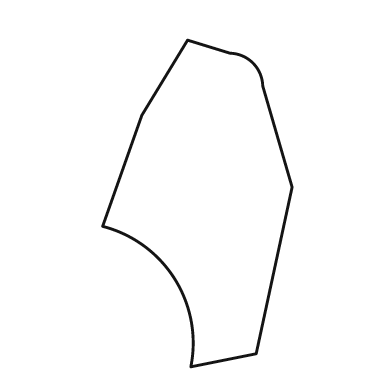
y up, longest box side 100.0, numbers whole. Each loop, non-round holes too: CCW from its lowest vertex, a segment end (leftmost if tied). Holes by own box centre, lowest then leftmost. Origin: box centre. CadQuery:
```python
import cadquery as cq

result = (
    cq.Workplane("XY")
    .moveTo(-2.0, -50.0)
    .lineTo(18.0, -46.0)
    .lineTo(29.0, 5.0)
    .lineTo(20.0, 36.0)
    .threePointArc((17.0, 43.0), (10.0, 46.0))
    .lineTo(-3.0, 50.0)
    .lineTo(-17.0, 27.0)
    .lineTo(-29.0, -7.0)
    .threePointArc((-7.0, -23.0), (-2.0, -50.0))
    .close()
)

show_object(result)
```